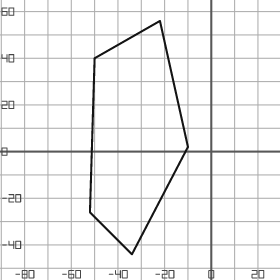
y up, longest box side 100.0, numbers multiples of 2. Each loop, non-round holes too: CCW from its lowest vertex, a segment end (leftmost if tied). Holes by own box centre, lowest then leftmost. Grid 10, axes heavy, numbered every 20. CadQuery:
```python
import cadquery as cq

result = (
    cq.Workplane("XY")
    .moveTo(-34.0, -44.0)
    .lineTo(-10.0, 2.0)
    .lineTo(-22.0, 56.0)
    .lineTo(-50.0, 40.0)
    .lineTo(-52.0, -26.0)
    .close()
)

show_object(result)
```